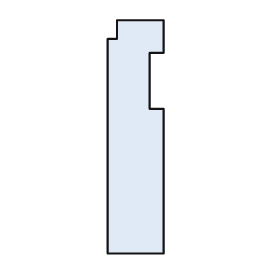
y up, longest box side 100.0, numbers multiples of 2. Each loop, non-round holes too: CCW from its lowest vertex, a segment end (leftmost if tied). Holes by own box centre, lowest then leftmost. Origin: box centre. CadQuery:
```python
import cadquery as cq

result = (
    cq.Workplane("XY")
    .moveTo(-12.0, -50.0)
    .lineTo(12.0, -50.0)
    .lineTo(12.0, 12.0)
    .lineTo(6.0, 12.0)
    .lineTo(6.0, 36.0)
    .lineTo(12.0, 36.0)
    .lineTo(12.0, 50.0)
    .lineTo(-8.0, 50.0)
    .lineTo(-8.0, 42.0)
    .lineTo(-12.0, 42.0)
    .close()
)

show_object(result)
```